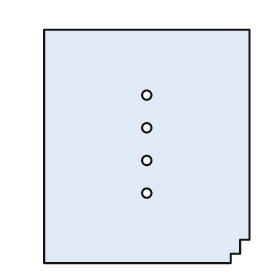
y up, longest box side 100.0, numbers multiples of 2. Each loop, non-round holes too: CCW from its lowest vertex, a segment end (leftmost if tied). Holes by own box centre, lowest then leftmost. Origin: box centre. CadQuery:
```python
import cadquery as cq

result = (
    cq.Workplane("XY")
    .moveTo(-44.0, -50.0)
    .lineTo(36.0, -50.0)
    .lineTo(36.0, -46.0)
    .lineTo(40.0, -46.0)
    .lineTo(40.0, -40.0)
    .lineTo(44.0, -40.0)
    .lineTo(44.0, 50.0)
    .lineTo(-44.0, 50.0)
    .close()
    .moveTo(0.0, -20.0)
    .circle(2.0)
    .moveTo(0.0, -6.0)
    .circle(2.0)
    .moveTo(0.0, 8.0)
    .circle(2.0)
    .moveTo(0.0, 22.0)
    .circle(2.0)
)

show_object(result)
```